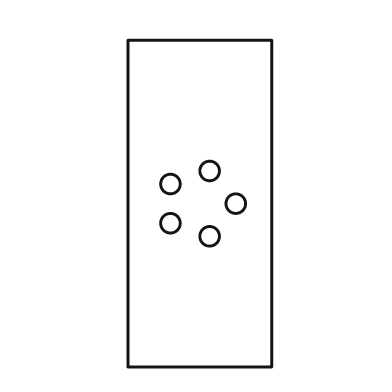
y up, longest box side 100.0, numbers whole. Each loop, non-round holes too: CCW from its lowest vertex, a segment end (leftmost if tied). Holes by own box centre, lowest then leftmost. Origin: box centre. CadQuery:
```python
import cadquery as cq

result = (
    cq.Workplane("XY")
    .moveTo(-22.0, -50.0)
    .lineTo(22.0, -50.0)
    .lineTo(22.0, 50.0)
    .lineTo(-22.0, 50.0)
    .close()
    .moveTo(3.0, -10.0)
    .circle(3.0)
    .moveTo(-9.0, -6.0)
    .circle(3.0)
    .moveTo(11.0, 0.0)
    .circle(3.0)
    .moveTo(-9.0, 6.0)
    .circle(3.0)
    .moveTo(3.0, 10.0)
    .circle(3.0)
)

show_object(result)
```